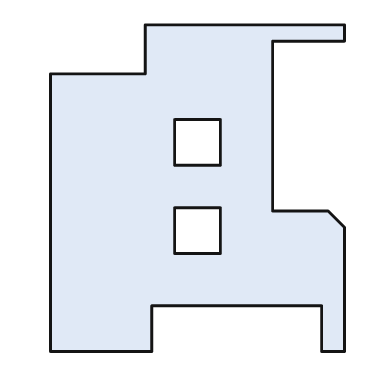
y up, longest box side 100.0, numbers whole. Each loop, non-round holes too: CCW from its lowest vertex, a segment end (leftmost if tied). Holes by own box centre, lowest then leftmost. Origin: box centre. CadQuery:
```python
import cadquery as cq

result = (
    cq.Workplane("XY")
    .moveTo(-45.0, -50.0)
    .lineTo(-14.0, -50.0)
    .lineTo(-14.0, -36.0)
    .lineTo(38.0, -36.0)
    .lineTo(38.0, -50.0)
    .lineTo(45.0, -50.0)
    .lineTo(45.0, -12.0)
    .lineTo(40.0, -7.0)
    .lineTo(23.0, -7.0)
    .lineTo(23.0, 45.0)
    .lineTo(45.0, 45.0)
    .lineTo(45.0, 50.0)
    .lineTo(-16.0, 50.0)
    .lineTo(-16.0, 35.0)
    .lineTo(-45.0, 35.0)
    .close()
    .moveTo(-7.0, -20.0)
    .lineTo(7.0, -20.0)
    .lineTo(7.0, -6.0)
    .lineTo(-7.0, -6.0)
    .close()
    .moveTo(-7.0, 7.0)
    .lineTo(7.0, 7.0)
    .lineTo(7.0, 21.0)
    .lineTo(-7.0, 21.0)
    .close()
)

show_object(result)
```